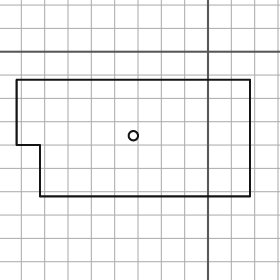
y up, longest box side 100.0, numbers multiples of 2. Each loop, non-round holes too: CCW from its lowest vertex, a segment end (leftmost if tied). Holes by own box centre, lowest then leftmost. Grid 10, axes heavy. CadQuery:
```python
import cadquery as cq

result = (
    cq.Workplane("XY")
    .moveTo(-72.0, -62.0)
    .lineTo(18.0, -62.0)
    .lineTo(18.0, -12.0)
    .lineTo(-82.0, -12.0)
    .lineTo(-82.0, -40.0)
    .lineTo(-72.0, -40.0)
    .close()
    .moveTo(-32.0, -36.0)
    .circle(2.0)
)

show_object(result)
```